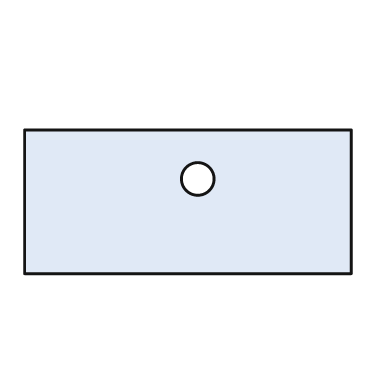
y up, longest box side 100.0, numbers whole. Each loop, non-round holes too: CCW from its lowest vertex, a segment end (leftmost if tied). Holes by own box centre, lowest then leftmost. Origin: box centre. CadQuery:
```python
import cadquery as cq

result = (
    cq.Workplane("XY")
    .moveTo(-50.0, -22.0)
    .lineTo(50.0, -22.0)
    .lineTo(50.0, 22.0)
    .lineTo(-50.0, 22.0)
    .close()
    .moveTo(3.0, 7.0)
    .circle(5.0)
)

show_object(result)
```